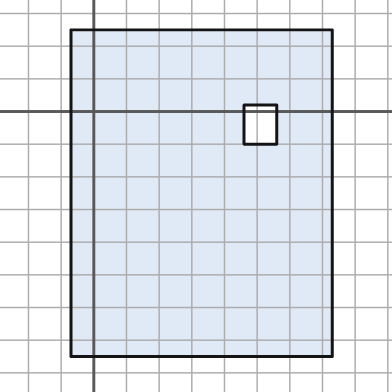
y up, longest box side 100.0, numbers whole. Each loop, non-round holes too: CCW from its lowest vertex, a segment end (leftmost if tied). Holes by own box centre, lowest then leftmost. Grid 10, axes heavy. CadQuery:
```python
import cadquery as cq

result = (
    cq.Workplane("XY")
    .moveTo(-7.0, -75.0)
    .lineTo(73.0, -75.0)
    .lineTo(73.0, 25.0)
    .lineTo(-7.0, 25.0)
    .close()
    .moveTo(46.0, -10.0)
    .lineTo(56.0, -10.0)
    .lineTo(56.0, 2.0)
    .lineTo(46.0, 2.0)
    .close()
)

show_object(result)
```